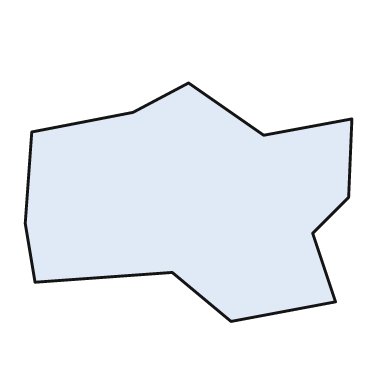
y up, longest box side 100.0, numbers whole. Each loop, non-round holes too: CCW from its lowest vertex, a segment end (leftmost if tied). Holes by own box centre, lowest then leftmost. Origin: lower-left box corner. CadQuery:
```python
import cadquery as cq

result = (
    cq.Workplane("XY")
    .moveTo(63.0, 0.0)
    .lineTo(95.0, 6.0)
    .lineTo(88.0, 27.0)
    .lineTo(99.0, 38.0)
    .lineTo(100.0, 62.0)
    .lineTo(73.0, 57.0)
    .lineTo(50.0, 73.0)
    .lineTo(33.0, 64.0)
    .lineTo(2.0, 58.0)
    .lineTo(0.0, 30.0)
    .lineTo(3.0, 12.0)
    .lineTo(45.0, 15.0)
    .close()
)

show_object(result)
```